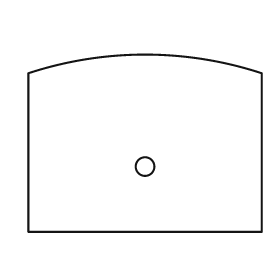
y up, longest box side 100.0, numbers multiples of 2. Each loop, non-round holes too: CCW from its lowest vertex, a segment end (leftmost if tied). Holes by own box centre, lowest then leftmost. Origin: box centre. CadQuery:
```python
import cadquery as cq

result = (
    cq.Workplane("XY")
    .moveTo(-50.0, -38.0)
    .lineTo(50.0, -38.0)
    .lineTo(50.0, 30.0)
    .threePointArc((0.0, 38.0), (-50.0, 30.0))
    .close()
    .moveTo(0.0, -10.0)
    .circle(4.0)
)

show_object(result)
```